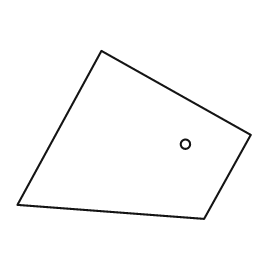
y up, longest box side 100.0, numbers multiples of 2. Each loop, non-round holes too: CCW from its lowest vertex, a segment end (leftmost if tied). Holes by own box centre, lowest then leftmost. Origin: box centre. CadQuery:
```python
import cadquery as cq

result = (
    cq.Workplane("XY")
    .moveTo(30.0, -36.0)
    .lineTo(50.0, 0.0)
    .lineTo(-14.0, 36.0)
    .lineTo(-50.0, -30.0)
    .close()
    .moveTo(22.0, -4.0)
    .circle(2.0)
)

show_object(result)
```